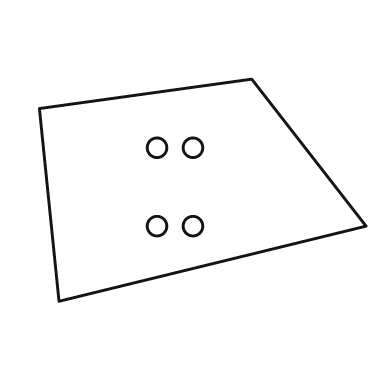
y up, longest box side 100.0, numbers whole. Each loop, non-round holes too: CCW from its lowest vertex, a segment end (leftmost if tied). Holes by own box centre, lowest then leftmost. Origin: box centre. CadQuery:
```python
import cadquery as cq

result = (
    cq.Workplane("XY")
    .moveTo(-44.0, -34.0)
    .lineTo(50.0, -11.0)
    .lineTo(15.0, 34.0)
    .lineTo(-50.0, 25.0)
    .close()
    .moveTo(-14.0, -11.0)
    .circle(3.0)
    .moveTo(-3.0, -11.0)
    .circle(3.0)
    .moveTo(-14.0, 13.0)
    .circle(3.0)
    .moveTo(-3.0, 13.0)
    .circle(3.0)
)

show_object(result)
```